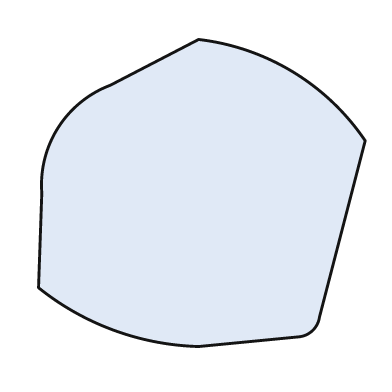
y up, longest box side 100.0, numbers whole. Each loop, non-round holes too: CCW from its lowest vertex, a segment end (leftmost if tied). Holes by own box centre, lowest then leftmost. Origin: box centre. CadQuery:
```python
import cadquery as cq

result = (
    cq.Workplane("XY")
    .moveTo(-1.0, -47.0)
    .lineTo(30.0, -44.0)
    .threePointArc((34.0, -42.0), (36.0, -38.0))
    .lineTo(50.0, 16.0)
    .threePointArc((28.0, 37.0), (-1.0, 47.0))
    .lineTo(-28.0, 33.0)
    .threePointArc((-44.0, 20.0), (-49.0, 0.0))
    .lineTo(-50.0, -29.0)
    .threePointArc((-27.0, -42.0), (-1.0, -47.0))
    .close()
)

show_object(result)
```